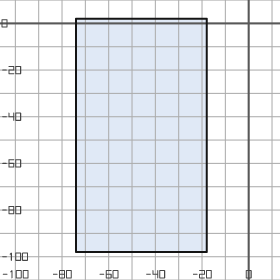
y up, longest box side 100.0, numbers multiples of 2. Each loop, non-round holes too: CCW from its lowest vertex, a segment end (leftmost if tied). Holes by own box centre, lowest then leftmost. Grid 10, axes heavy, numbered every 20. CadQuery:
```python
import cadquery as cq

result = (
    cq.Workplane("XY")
    .moveTo(-74.0, -98.0)
    .lineTo(-18.0, -98.0)
    .lineTo(-18.0, 2.0)
    .lineTo(-74.0, 2.0)
    .close()
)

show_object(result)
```